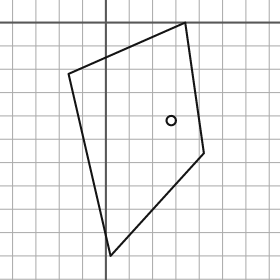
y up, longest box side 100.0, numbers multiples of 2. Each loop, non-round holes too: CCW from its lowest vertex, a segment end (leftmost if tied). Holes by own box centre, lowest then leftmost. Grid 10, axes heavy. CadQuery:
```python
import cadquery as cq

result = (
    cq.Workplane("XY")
    .moveTo(2.0, -100.0)
    .lineTo(42.0, -56.0)
    .lineTo(34.0, 0.0)
    .lineTo(-16.0, -22.0)
    .close()
    .moveTo(28.0, -42.0)
    .circle(2.0)
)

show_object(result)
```